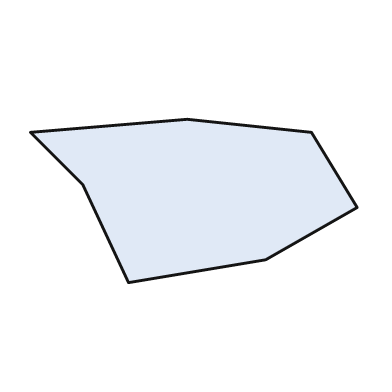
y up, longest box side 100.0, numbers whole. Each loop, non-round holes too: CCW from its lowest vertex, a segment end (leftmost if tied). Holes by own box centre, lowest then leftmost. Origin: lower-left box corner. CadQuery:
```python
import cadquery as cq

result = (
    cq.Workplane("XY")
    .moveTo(30.0, 0.0)
    .lineTo(72.0, 7.0)
    .lineTo(100.0, 23.0)
    .lineTo(86.0, 46.0)
    .lineTo(48.0, 50.0)
    .lineTo(0.0, 46.0)
    .lineTo(16.0, 30.0)
    .close()
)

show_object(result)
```